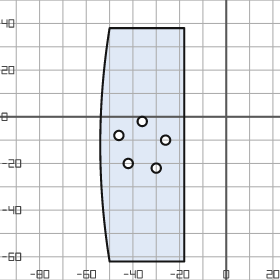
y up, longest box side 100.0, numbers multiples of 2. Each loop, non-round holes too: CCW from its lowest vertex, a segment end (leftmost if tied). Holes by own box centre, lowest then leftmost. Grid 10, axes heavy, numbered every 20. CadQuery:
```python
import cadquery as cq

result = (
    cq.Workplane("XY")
    .moveTo(-50.0, -62.0)
    .lineTo(-18.0, -62.0)
    .lineTo(-18.0, 38.0)
    .lineTo(-50.0, 38.0)
    .threePointArc((-54.0, -12.0), (-50.0, -62.0))
    .close()
    .moveTo(-30.0, -22.0)
    .circle(2.0)
    .moveTo(-42.0, -20.0)
    .circle(2.0)
    .moveTo(-26.0, -10.0)
    .circle(2.0)
    .moveTo(-46.0, -8.0)
    .circle(2.0)
    .moveTo(-36.0, -2.0)
    .circle(2.0)
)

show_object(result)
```